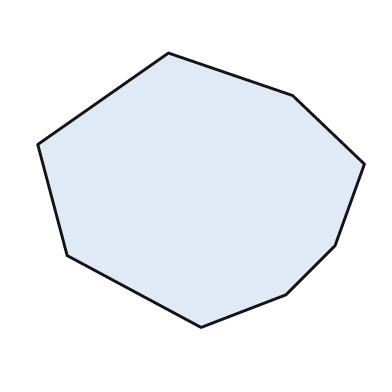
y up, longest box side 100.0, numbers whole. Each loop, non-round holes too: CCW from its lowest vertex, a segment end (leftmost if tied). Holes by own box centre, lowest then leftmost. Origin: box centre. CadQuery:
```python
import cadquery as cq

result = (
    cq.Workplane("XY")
    .moveTo(0.0, -42.0)
    .lineTo(26.0, -32.0)
    .lineTo(41.0, -17.0)
    .lineTo(50.0, 8.0)
    .lineTo(28.0, 29.0)
    .lineTo(-10.0, 42.0)
    .lineTo(-50.0, 14.0)
    .lineTo(-41.0, -20.0)
    .close()
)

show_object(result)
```